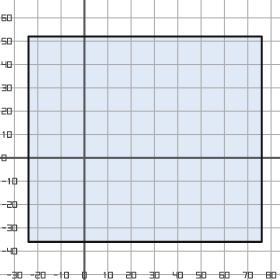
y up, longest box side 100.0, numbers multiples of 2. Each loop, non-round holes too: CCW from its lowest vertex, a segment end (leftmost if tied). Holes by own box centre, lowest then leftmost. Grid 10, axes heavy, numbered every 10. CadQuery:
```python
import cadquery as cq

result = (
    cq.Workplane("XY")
    .moveTo(-24.0, -36.0)
    .lineTo(76.0, -36.0)
    .lineTo(76.0, 52.0)
    .lineTo(-24.0, 52.0)
    .close()
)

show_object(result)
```